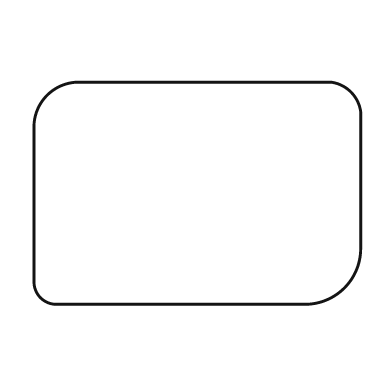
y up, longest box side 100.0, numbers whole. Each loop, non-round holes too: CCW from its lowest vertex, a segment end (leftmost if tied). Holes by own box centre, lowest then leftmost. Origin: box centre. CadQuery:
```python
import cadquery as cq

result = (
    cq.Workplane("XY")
    .moveTo(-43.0, -34.0)
    .lineTo(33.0, -34.0)
    .threePointArc((45.0, -29.0), (50.0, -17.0))
    .lineTo(50.0, 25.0)
    .threePointArc((47.0, 31.0), (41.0, 34.0))
    .lineTo(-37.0, 34.0)
    .threePointArc((-46.0, 30.0), (-50.0, 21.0))
    .lineTo(-50.0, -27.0)
    .threePointArc((-48.0, -32.0), (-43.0, -34.0))
    .close()
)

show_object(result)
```